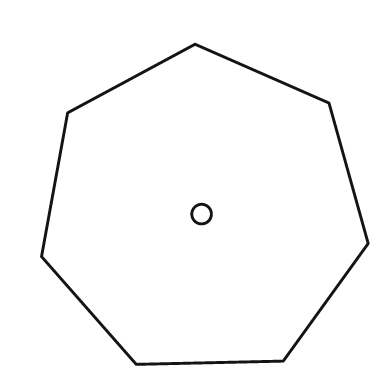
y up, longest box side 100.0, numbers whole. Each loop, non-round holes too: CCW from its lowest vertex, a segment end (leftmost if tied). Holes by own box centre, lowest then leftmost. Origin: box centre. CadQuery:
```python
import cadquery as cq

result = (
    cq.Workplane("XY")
    .moveTo(-21.0, -49.0)
    .lineTo(24.0, -48.0)
    .lineTo(50.0, -12.0)
    .lineTo(38.0, 31.0)
    .lineTo(-3.0, 49.0)
    .lineTo(-42.0, 28.0)
    .lineTo(-50.0, -16.0)
    .close()
    .moveTo(-1.0, -3.0)
    .circle(3.0)
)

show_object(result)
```